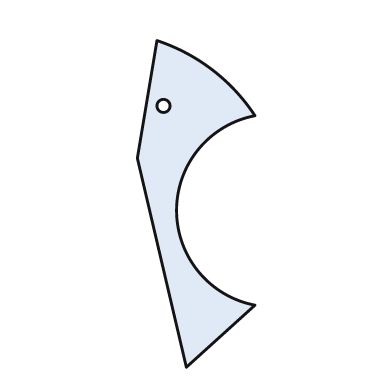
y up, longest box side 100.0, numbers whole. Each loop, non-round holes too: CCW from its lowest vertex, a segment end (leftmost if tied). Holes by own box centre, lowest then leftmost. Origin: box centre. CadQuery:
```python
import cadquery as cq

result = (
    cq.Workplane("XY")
    .moveTo(-3.0, -50.0)
    .lineTo(18.0, -31.0)
    .threePointArc((-6.0, -2.0), (18.0, 27.0))
    .threePointArc((5.0, 41.0), (-12.0, 50.0))
    .lineTo(-18.0, 14.0)
    .close()
    .moveTo(-10.0, 30.0)
    .circle(2.0)
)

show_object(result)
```